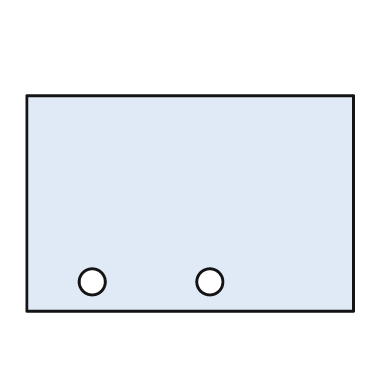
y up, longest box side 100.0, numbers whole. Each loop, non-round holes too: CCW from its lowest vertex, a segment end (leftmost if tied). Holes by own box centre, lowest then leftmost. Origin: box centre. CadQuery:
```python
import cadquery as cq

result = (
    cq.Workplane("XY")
    .moveTo(-50.0, -33.0)
    .lineTo(50.0, -33.0)
    .lineTo(50.0, 33.0)
    .lineTo(-50.0, 33.0)
    .close()
    .moveTo(-30.0, -24.0)
    .circle(4.0)
    .moveTo(6.0, -24.0)
    .circle(4.0)
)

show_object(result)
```